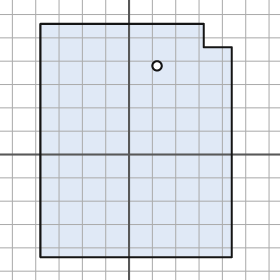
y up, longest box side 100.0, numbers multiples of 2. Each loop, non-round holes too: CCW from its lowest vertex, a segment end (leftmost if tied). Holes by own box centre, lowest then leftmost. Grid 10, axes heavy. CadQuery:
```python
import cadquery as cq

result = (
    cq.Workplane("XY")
    .moveTo(-38.0, -44.0)
    .lineTo(44.0, -44.0)
    .lineTo(44.0, 46.0)
    .lineTo(32.0, 46.0)
    .lineTo(32.0, 56.0)
    .lineTo(-38.0, 56.0)
    .close()
    .moveTo(12.0, 38.0)
    .circle(2.0)
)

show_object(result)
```